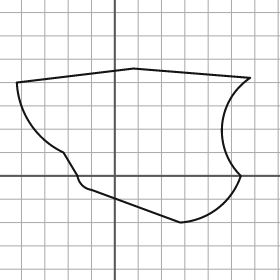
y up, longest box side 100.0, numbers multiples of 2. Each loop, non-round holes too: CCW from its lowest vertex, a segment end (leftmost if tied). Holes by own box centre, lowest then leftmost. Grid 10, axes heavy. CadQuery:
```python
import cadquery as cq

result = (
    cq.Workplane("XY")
    .moveTo(28.0, -20.0)
    .threePointArc((44.0, -14.0), (54.0, 0.0))
    .threePointArc((46.0, 22.0), (58.0, 42.0))
    .lineTo(8.0, 46.0)
    .lineTo(-42.0, 40.0)
    .threePointArc((-36.0, 22.0), (-22.0, 10.0))
    .lineTo(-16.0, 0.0)
    .threePointArc((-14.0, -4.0), (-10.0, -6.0))
    .close()
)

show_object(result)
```